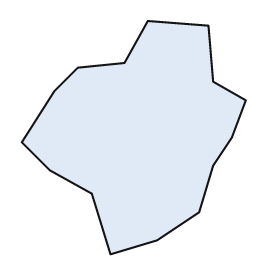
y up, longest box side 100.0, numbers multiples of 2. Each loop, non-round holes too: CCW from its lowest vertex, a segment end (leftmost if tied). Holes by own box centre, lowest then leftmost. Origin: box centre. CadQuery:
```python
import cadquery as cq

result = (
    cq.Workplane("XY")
    .moveTo(-10.0, -50.0)
    .lineTo(10.0, -44.0)
    .lineTo(28.0, -32.0)
    .lineTo(34.0, -12.0)
    .lineTo(42.0, 0.0)
    .lineTo(48.0, 16.0)
    .lineTo(34.0, 24.0)
    .lineTo(32.0, 48.0)
    .lineTo(6.0, 50.0)
    .lineTo(-4.0, 32.0)
    .lineTo(-24.0, 30.0)
    .lineTo(-34.0, 20.0)
    .lineTo(-48.0, -2.0)
    .lineTo(-36.0, -14.0)
    .lineTo(-18.0, -24.0)
    .close()
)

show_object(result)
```